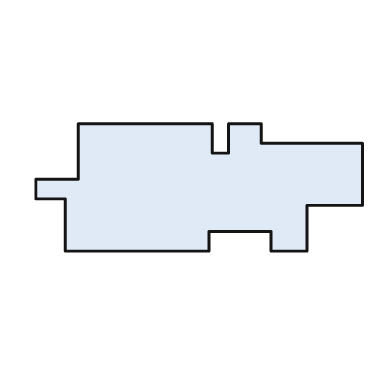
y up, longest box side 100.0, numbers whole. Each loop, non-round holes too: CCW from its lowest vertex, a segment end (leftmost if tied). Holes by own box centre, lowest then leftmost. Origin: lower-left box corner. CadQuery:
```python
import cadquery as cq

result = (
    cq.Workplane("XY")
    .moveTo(9.0, 0.0)
    .lineTo(53.0, 0.0)
    .lineTo(53.0, 6.0)
    .lineTo(72.0, 6.0)
    .lineTo(72.0, 0.0)
    .lineTo(83.0, 0.0)
    .lineTo(83.0, 14.0)
    .lineTo(100.0, 14.0)
    .lineTo(100.0, 33.0)
    .lineTo(69.0, 33.0)
    .lineTo(69.0, 39.0)
    .lineTo(59.0, 39.0)
    .lineTo(59.0, 30.0)
    .lineTo(54.0, 30.0)
    .lineTo(54.0, 39.0)
    .lineTo(13.0, 39.0)
    .lineTo(13.0, 22.0)
    .lineTo(0.0, 22.0)
    .lineTo(0.0, 16.0)
    .lineTo(9.0, 16.0)
    .close()
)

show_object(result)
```